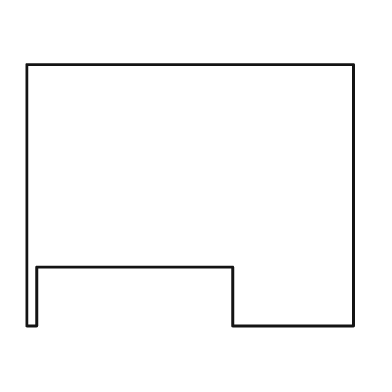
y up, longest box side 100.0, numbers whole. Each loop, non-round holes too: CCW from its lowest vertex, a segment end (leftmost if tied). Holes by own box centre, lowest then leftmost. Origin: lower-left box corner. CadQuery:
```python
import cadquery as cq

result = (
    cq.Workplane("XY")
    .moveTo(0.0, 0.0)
    .lineTo(3.0, 0.0)
    .lineTo(3.0, 18.0)
    .lineTo(63.0, 18.0)
    .lineTo(63.0, 0.0)
    .lineTo(100.0, 0.0)
    .lineTo(100.0, 80.0)
    .lineTo(0.0, 80.0)
    .close()
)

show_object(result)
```